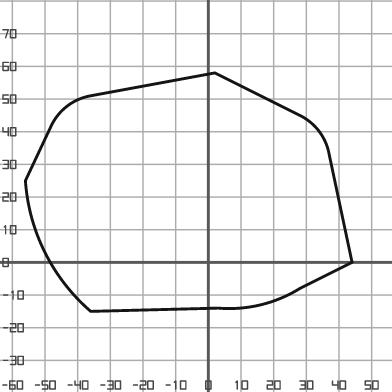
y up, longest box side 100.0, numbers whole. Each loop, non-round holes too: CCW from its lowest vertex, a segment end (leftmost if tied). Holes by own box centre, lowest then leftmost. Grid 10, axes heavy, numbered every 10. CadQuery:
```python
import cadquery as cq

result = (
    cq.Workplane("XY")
    .moveTo(-36.0, -15.0)
    .lineTo(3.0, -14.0)
    .threePointArc((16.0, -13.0), (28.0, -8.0))
    .lineTo(44.0, 0.0)
    .lineTo(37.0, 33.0)
    .threePointArc((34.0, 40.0), (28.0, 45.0))
    .lineTo(2.0, 58.0)
    .lineTo(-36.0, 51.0)
    .threePointArc((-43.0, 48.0), (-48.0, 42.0))
    .lineTo(-56.0, 25.0)
    .threePointArc((-50.0, 3.0), (-36.0, -15.0))
    .close()
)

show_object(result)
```